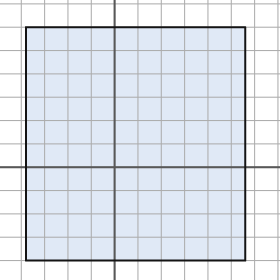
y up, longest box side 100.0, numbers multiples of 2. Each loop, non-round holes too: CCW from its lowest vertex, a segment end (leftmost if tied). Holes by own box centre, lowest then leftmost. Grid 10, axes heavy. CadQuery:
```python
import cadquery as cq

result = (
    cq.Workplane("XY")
    .moveTo(-38.0, -40.0)
    .lineTo(56.0, -40.0)
    .lineTo(56.0, 60.0)
    .lineTo(-38.0, 60.0)
    .close()
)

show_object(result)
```